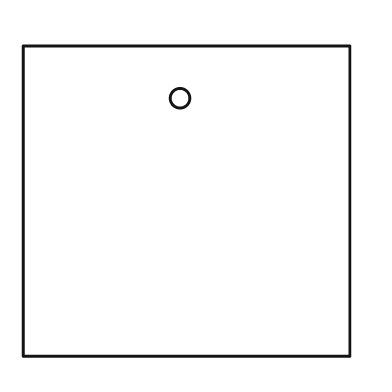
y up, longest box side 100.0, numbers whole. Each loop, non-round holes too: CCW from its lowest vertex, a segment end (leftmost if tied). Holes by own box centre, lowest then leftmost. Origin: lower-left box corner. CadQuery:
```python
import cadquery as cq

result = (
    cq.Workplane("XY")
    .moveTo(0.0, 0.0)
    .lineTo(100.0, 0.0)
    .lineTo(100.0, 95.0)
    .lineTo(0.0, 95.0)
    .close()
    .moveTo(48.0, 79.0)
    .circle(3.0)
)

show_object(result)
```